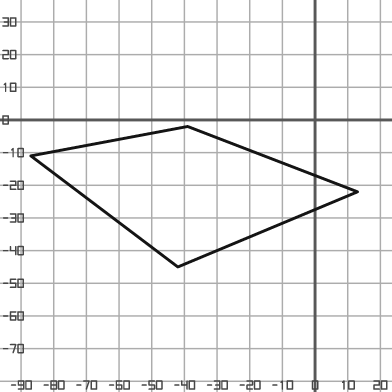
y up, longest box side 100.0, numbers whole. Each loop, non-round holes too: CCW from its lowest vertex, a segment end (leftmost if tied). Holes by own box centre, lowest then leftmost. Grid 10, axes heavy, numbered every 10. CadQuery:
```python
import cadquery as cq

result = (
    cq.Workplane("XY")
    .moveTo(-42.0, -45.0)
    .lineTo(13.0, -22.0)
    .lineTo(-39.0, -2.0)
    .lineTo(-87.0, -11.0)
    .close()
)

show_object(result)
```